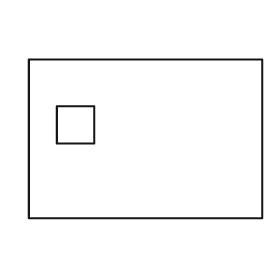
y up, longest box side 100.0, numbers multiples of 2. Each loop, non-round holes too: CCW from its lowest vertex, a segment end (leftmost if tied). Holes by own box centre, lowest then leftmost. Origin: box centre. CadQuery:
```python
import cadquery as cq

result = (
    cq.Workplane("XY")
    .moveTo(-50.0, -34.0)
    .lineTo(50.0, -34.0)
    .lineTo(50.0, 34.0)
    .lineTo(-50.0, 34.0)
    .close()
    .moveTo(-38.0, -2.0)
    .lineTo(-22.0, -2.0)
    .lineTo(-22.0, 14.0)
    .lineTo(-38.0, 14.0)
    .close()
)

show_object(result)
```